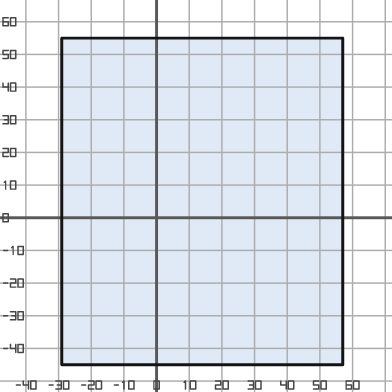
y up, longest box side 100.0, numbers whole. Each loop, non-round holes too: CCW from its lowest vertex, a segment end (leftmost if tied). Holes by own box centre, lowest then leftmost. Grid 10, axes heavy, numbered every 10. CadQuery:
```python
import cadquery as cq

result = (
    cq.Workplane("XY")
    .moveTo(-29.0, -45.0)
    .lineTo(57.0, -45.0)
    .lineTo(57.0, 55.0)
    .lineTo(-29.0, 55.0)
    .close()
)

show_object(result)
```